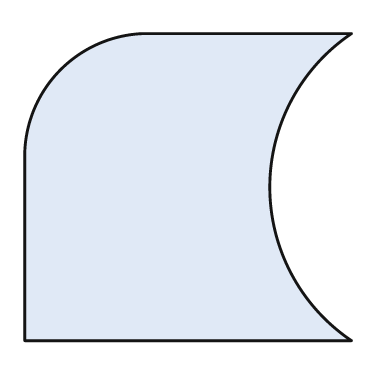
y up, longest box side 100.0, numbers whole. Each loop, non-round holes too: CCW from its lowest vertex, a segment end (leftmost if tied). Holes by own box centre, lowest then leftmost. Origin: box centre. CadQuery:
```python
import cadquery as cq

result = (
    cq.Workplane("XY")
    .moveTo(-50.0, -47.0)
    .lineTo(50.0, -47.0)
    .threePointArc((25.0, 0.0), (50.0, 47.0))
    .lineTo(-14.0, 47.0)
    .threePointArc((-39.0, 36.0), (-50.0, 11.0))
    .close()
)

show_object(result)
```